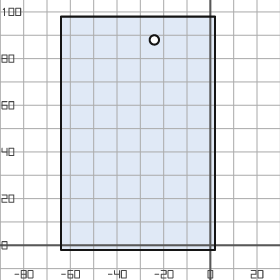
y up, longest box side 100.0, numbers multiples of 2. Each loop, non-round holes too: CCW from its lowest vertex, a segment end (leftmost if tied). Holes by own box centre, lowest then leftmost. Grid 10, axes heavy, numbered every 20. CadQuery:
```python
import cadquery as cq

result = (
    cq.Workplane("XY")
    .moveTo(-64.0, -2.0)
    .lineTo(2.0, -2.0)
    .lineTo(2.0, 98.0)
    .lineTo(-64.0, 98.0)
    .close()
    .moveTo(-24.0, 88.0)
    .circle(2.0)
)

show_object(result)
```